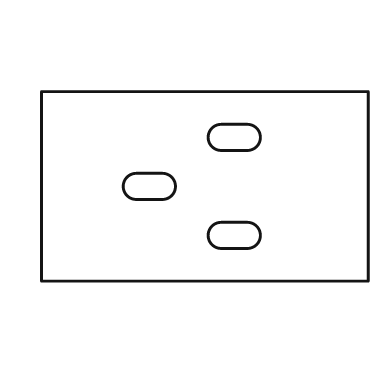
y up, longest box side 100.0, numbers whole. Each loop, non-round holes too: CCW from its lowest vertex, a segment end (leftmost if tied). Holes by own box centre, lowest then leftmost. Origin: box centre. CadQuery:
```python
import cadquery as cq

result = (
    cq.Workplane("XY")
    .moveTo(-50.0, -29.0)
    .lineTo(50.0, -29.0)
    .lineTo(50.0, 29.0)
    .lineTo(-50.0, 29.0)
    .close()
    .moveTo(5.0, -19.0)
    .lineTo(13.0, -19.0)
    .threePointArc((17.0, -15.0), (13.0, -11.0))
    .lineTo(5.0, -11.0)
    .threePointArc((1.0, -15.0), (5.0, -19.0))
    .close()
    .moveTo(-21.0, -4.0)
    .lineTo(-13.0, -4.0)
    .threePointArc((-9.0, 0.0), (-13.0, 4.0))
    .lineTo(-21.0, 4.0)
    .threePointArc((-25.0, 0.0), (-21.0, -4.0))
    .close()
    .moveTo(5.0, 11.0)
    .lineTo(13.0, 11.0)
    .threePointArc((17.0, 15.0), (13.0, 19.0))
    .lineTo(5.0, 19.0)
    .threePointArc((1.0, 15.0), (5.0, 11.0))
    .close()
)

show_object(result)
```